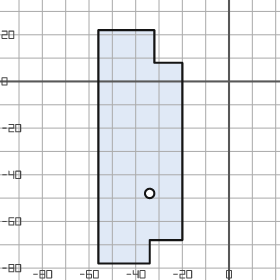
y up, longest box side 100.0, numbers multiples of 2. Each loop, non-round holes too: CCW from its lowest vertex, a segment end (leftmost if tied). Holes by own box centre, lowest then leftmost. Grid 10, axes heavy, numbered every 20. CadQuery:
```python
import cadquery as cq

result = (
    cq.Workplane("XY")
    .moveTo(-56.0, -78.0)
    .lineTo(-34.0, -78.0)
    .lineTo(-34.0, -68.0)
    .lineTo(-20.0, -68.0)
    .lineTo(-20.0, 8.0)
    .lineTo(-32.0, 8.0)
    .lineTo(-32.0, 22.0)
    .lineTo(-56.0, 22.0)
    .close()
    .moveTo(-34.0, -48.0)
    .circle(2.0)
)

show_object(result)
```